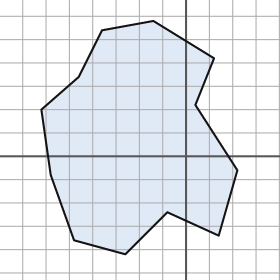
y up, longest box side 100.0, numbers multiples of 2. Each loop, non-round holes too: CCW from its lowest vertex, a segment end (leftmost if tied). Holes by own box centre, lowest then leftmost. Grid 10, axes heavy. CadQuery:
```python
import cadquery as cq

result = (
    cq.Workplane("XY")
    .moveTo(-26.0, -42.0)
    .lineTo(-8.0, -24.0)
    .lineTo(14.0, -34.0)
    .lineTo(22.0, -6.0)
    .lineTo(4.0, 22.0)
    .lineTo(12.0, 42.0)
    .lineTo(-14.0, 58.0)
    .lineTo(-36.0, 54.0)
    .lineTo(-46.0, 34.0)
    .lineTo(-62.0, 20.0)
    .lineTo(-58.0, -8.0)
    .lineTo(-48.0, -36.0)
    .close()
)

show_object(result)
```